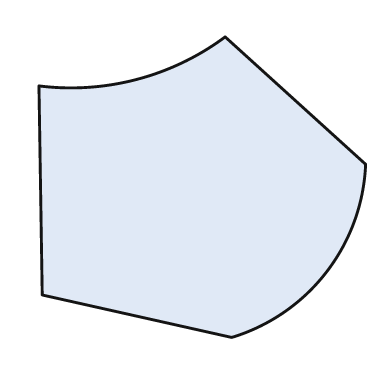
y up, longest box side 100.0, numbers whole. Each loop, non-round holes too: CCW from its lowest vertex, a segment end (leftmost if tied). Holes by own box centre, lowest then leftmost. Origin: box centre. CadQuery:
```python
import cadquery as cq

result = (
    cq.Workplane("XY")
    .moveTo(9.0, -46.0)
    .threePointArc((38.0, -26.0), (50.0, 7.0))
    .lineTo(7.0, 46.0)
    .threePointArc((-20.0, 33.0), (-50.0, 31.0))
    .lineTo(-49.0, -33.0)
    .close()
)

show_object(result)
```